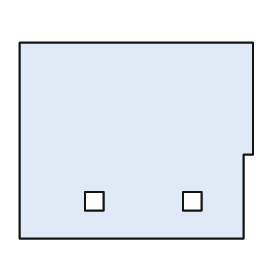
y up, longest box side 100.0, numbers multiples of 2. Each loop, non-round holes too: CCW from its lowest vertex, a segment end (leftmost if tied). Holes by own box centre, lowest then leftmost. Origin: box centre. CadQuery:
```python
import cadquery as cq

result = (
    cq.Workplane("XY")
    .moveTo(-50.0, -42.0)
    .lineTo(46.0, -42.0)
    .lineTo(46.0, -6.0)
    .lineTo(50.0, -6.0)
    .lineTo(50.0, 42.0)
    .lineTo(-50.0, 42.0)
    .close()
    .moveTo(-22.0, -30.0)
    .lineTo(-14.0, -30.0)
    .lineTo(-14.0, -22.0)
    .lineTo(-22.0, -22.0)
    .close()
    .moveTo(20.0, -30.0)
    .lineTo(28.0, -30.0)
    .lineTo(28.0, -22.0)
    .lineTo(20.0, -22.0)
    .close()
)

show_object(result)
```